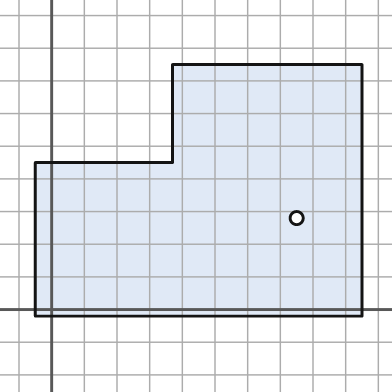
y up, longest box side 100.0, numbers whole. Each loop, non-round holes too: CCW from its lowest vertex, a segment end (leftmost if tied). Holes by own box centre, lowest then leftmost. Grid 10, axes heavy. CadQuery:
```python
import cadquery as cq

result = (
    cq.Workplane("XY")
    .moveTo(-5.0, -2.0)
    .lineTo(95.0, -2.0)
    .lineTo(95.0, 75.0)
    .lineTo(37.0, 75.0)
    .lineTo(37.0, 45.0)
    .lineTo(-5.0, 45.0)
    .close()
    .moveTo(75.0, 28.0)
    .circle(2.0)
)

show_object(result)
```